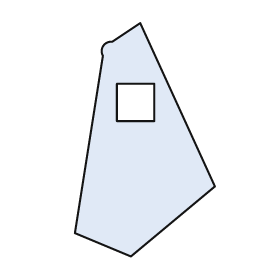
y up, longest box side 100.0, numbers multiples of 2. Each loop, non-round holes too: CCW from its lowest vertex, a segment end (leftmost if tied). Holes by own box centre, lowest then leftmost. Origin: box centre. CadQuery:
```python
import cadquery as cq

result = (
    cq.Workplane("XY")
    .moveTo(-6.0, -50.0)
    .lineTo(30.0, -20.0)
    .lineTo(-2.0, 50.0)
    .lineTo(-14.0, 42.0)
    .threePointArc((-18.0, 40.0), (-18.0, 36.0))
    .lineTo(-30.0, -40.0)
    .close()
    .moveTo(-12.0, 8.0)
    .lineTo(4.0, 8.0)
    .lineTo(4.0, 24.0)
    .lineTo(-12.0, 24.0)
    .close()
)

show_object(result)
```